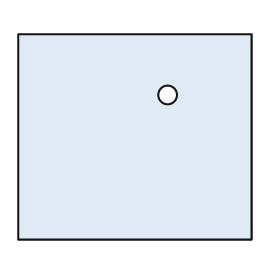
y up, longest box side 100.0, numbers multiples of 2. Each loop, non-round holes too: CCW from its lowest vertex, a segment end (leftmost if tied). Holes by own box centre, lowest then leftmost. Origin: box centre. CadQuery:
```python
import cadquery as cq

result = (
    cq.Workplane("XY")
    .moveTo(-50.0, -44.0)
    .lineTo(50.0, -44.0)
    .lineTo(50.0, 44.0)
    .lineTo(-50.0, 44.0)
    .close()
    .moveTo(14.0, 18.0)
    .circle(4.0)
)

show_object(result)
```